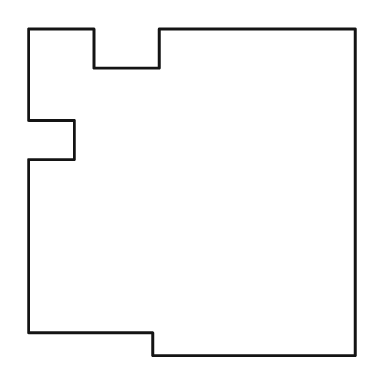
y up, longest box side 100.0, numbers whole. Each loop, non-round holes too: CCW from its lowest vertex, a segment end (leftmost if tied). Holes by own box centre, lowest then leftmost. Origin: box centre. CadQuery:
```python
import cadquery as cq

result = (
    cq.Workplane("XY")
    .moveTo(-12.0, -50.0)
    .lineTo(50.0, -50.0)
    .lineTo(50.0, 50.0)
    .lineTo(-10.0, 50.0)
    .lineTo(-10.0, 38.0)
    .lineTo(-30.0, 38.0)
    .lineTo(-30.0, 50.0)
    .lineTo(-50.0, 50.0)
    .lineTo(-50.0, 22.0)
    .lineTo(-36.0, 22.0)
    .lineTo(-36.0, 10.0)
    .lineTo(-50.0, 10.0)
    .lineTo(-50.0, -43.0)
    .lineTo(-12.0, -43.0)
    .close()
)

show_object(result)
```